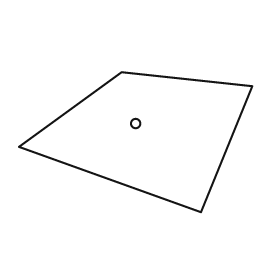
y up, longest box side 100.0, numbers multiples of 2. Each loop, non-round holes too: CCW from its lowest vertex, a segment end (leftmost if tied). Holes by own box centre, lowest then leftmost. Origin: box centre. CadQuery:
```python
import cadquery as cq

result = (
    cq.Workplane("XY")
    .moveTo(28.0, -30.0)
    .lineTo(50.0, 24.0)
    .lineTo(-6.0, 30.0)
    .lineTo(-50.0, -2.0)
    .close()
    .moveTo(0.0, 8.0)
    .circle(2.0)
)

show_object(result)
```